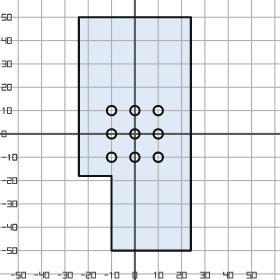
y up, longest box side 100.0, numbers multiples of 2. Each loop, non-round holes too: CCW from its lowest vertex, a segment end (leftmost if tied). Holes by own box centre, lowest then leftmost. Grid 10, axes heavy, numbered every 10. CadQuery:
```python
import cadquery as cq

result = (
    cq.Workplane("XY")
    .moveTo(-10.0, -50.0)
    .lineTo(24.0, -50.0)
    .lineTo(24.0, 50.0)
    .lineTo(-24.0, 50.0)
    .lineTo(-24.0, -18.0)
    .lineTo(-10.0, -18.0)
    .close()
    .moveTo(-10.0, -10.0)
    .circle(2.0)
    .moveTo(0.0, -10.0)
    .circle(2.0)
    .moveTo(10.0, -10.0)
    .circle(2.0)
    .moveTo(-10.0, 0.0)
    .circle(2.0)
    .moveTo(0.0, 0.0)
    .circle(2.0)
    .moveTo(10.0, 0.0)
    .circle(2.0)
    .moveTo(-10.0, 10.0)
    .circle(2.0)
    .moveTo(0.0, 10.0)
    .circle(2.0)
    .moveTo(10.0, 10.0)
    .circle(2.0)
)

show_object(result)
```